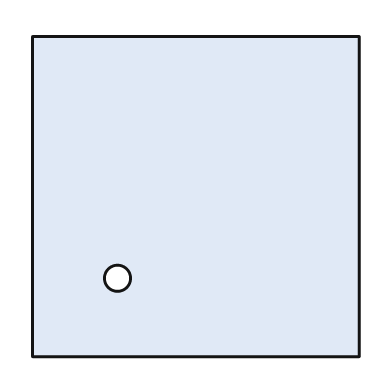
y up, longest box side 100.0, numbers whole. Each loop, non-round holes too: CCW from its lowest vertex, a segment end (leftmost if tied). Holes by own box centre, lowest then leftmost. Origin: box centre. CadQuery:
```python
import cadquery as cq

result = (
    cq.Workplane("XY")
    .moveTo(-50.0, -49.0)
    .lineTo(50.0, -49.0)
    .lineTo(50.0, 49.0)
    .lineTo(-50.0, 49.0)
    .close()
    .moveTo(-24.0, -25.0)
    .circle(4.0)
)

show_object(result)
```